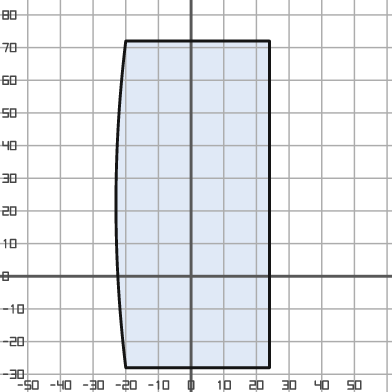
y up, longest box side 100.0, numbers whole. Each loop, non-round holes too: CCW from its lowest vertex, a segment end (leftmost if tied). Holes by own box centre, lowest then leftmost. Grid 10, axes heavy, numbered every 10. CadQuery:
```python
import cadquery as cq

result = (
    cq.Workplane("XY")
    .moveTo(-20.0, -28.0)
    .lineTo(24.0, -28.0)
    .lineTo(24.0, 72.0)
    .lineTo(-20.0, 72.0)
    .threePointArc((-23.0, 22.0), (-20.0, -28.0))
    .close()
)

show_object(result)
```